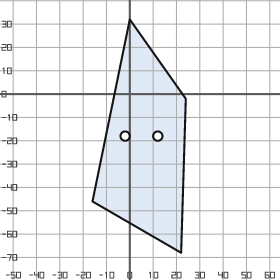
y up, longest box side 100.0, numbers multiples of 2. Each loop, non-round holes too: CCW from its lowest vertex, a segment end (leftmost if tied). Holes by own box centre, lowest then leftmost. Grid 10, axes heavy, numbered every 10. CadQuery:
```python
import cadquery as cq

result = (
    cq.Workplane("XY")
    .moveTo(22.0, -68.0)
    .lineTo(24.0, -2.0)
    .lineTo(0.0, 32.0)
    .lineTo(-16.0, -46.0)
    .close()
    .moveTo(-2.0, -18.0)
    .circle(2.0)
    .moveTo(12.0, -18.0)
    .circle(2.0)
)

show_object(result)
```